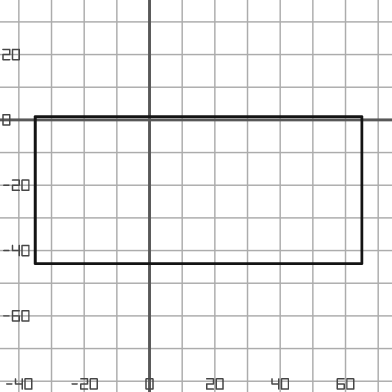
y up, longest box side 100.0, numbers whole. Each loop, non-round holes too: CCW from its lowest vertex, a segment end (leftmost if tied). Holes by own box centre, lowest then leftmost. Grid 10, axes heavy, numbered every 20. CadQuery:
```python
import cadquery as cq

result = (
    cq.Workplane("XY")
    .moveTo(-35.0, -44.0)
    .lineTo(65.0, -44.0)
    .lineTo(65.0, 1.0)
    .lineTo(-35.0, 1.0)
    .close()
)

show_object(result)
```